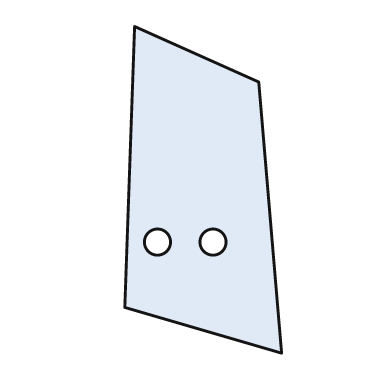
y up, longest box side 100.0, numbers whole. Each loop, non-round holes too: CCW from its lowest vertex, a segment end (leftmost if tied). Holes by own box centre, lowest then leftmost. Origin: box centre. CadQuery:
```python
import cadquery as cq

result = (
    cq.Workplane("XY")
    .moveTo(24.0, -50.0)
    .lineTo(17.0, 33.0)
    .lineTo(-21.0, 50.0)
    .lineTo(-24.0, -36.0)
    .close()
    .moveTo(-14.0, -16.0)
    .circle(4.0)
    .moveTo(3.0, -16.0)
    .circle(4.0)
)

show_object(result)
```